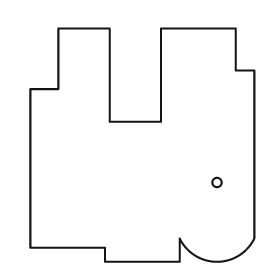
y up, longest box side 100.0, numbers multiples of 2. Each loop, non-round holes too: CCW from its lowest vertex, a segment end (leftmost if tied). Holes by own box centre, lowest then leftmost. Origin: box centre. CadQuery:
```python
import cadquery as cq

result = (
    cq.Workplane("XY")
    .moveTo(-16.0, -50.0)
    .lineTo(16.0, -50.0)
    .lineTo(16.0, -40.0)
    .threePointArc((32.0, -50.0), (48.0, -40.0))
    .lineTo(48.0, 32.0)
    .lineTo(40.0, 32.0)
    .lineTo(40.0, 50.0)
    .lineTo(8.0, 50.0)
    .lineTo(8.0, 10.0)
    .lineTo(-14.0, 10.0)
    .lineTo(-14.0, 50.0)
    .lineTo(-36.0, 50.0)
    .lineTo(-36.0, 24.0)
    .lineTo(-48.0, 24.0)
    .lineTo(-48.0, -44.0)
    .lineTo(-16.0, -44.0)
    .close()
    .moveTo(32.0, -16.0)
    .circle(2.0)
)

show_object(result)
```